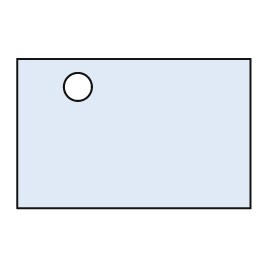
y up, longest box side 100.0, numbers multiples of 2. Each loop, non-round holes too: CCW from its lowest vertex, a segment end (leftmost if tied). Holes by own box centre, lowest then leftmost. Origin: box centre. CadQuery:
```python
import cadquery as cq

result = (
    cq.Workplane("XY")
    .moveTo(-50.0, -32.0)
    .lineTo(50.0, -32.0)
    .lineTo(50.0, 32.0)
    .lineTo(-50.0, 32.0)
    .close()
    .moveTo(-24.0, 20.0)
    .circle(6.0)
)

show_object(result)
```